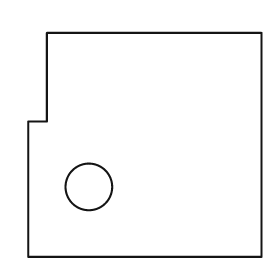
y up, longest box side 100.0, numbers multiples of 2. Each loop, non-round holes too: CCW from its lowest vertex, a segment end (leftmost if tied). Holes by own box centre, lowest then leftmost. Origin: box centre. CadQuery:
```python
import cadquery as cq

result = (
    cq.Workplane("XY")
    .moveTo(-50.0, -48.0)
    .lineTo(50.0, -48.0)
    .lineTo(50.0, 48.0)
    .lineTo(-42.0, 48.0)
    .lineTo(-42.0, 10.0)
    .lineTo(-50.0, 10.0)
    .close()
    .moveTo(-24.0, -18.0)
    .circle(10.0)
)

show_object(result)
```